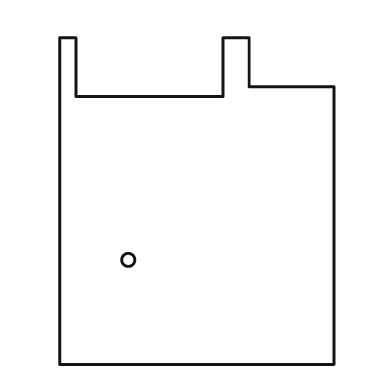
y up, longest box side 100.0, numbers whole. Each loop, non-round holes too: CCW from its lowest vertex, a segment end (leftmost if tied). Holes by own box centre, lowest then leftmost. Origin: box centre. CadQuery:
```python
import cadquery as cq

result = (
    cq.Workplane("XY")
    .moveTo(-42.0, -50.0)
    .lineTo(42.0, -50.0)
    .lineTo(42.0, 35.0)
    .lineTo(16.0, 35.0)
    .lineTo(16.0, 50.0)
    .lineTo(8.0, 50.0)
    .lineTo(8.0, 32.0)
    .lineTo(-37.0, 32.0)
    .lineTo(-37.0, 50.0)
    .lineTo(-42.0, 50.0)
    .close()
    .moveTo(-21.0, -18.0)
    .circle(2.0)
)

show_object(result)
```